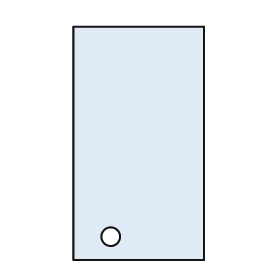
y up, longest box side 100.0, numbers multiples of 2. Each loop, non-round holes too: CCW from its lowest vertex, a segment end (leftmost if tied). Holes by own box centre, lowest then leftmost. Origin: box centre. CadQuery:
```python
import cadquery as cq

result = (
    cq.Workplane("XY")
    .moveTo(-28.0, -50.0)
    .lineTo(28.0, -50.0)
    .lineTo(28.0, 50.0)
    .lineTo(-28.0, 50.0)
    .close()
    .moveTo(-12.0, -40.0)
    .circle(4.0)
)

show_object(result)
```